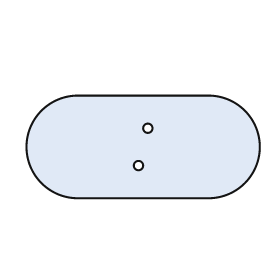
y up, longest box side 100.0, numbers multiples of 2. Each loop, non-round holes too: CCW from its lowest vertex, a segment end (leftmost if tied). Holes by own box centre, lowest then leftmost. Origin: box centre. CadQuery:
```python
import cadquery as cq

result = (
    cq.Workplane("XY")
    .moveTo(-28.0, -22.0)
    .lineTo(28.0, -22.0)
    .threePointArc((50.0, 0.0), (28.0, 22.0))
    .lineTo(-28.0, 22.0)
    .threePointArc((-50.0, 0.0), (-28.0, -22.0))
    .close()
    .moveTo(-2.0, -8.0)
    .circle(2.0)
    .moveTo(2.0, 8.0)
    .circle(2.0)
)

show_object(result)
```